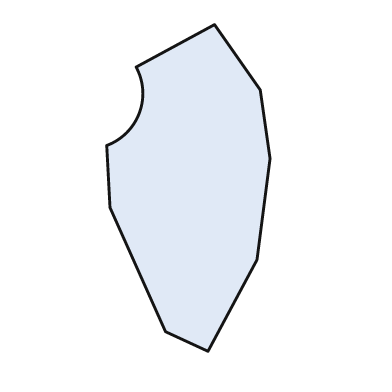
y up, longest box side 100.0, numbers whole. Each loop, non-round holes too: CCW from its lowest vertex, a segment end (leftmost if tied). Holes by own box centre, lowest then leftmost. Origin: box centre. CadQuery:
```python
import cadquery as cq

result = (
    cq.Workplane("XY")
    .moveTo(6.0, -50.0)
    .lineTo(21.0, -22.0)
    .lineTo(25.0, 9.0)
    .lineTo(22.0, 30.0)
    .lineTo(8.0, 50.0)
    .lineTo(-16.0, 37.0)
    .threePointArc((-15.0, 23.0), (-25.0, 13.0))
    .lineTo(-24.0, -6.0)
    .lineTo(-7.0, -44.0)
    .close()
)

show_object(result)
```